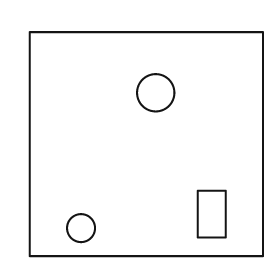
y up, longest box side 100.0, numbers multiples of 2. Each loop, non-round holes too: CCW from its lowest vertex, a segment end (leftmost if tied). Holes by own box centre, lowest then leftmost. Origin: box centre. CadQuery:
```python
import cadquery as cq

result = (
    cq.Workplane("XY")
    .moveTo(-50.0, -48.0)
    .lineTo(50.0, -48.0)
    .lineTo(50.0, 48.0)
    .lineTo(-50.0, 48.0)
    .close()
    .moveTo(-28.0, -36.0)
    .circle(6.0)
    .moveTo(22.0, -40.0)
    .lineTo(34.0, -40.0)
    .lineTo(34.0, -20.0)
    .lineTo(22.0, -20.0)
    .close()
    .moveTo(4.0, 22.0)
    .circle(8.0)
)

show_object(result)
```